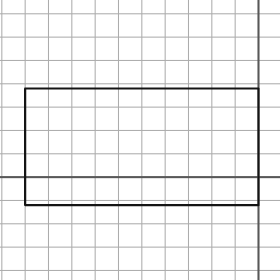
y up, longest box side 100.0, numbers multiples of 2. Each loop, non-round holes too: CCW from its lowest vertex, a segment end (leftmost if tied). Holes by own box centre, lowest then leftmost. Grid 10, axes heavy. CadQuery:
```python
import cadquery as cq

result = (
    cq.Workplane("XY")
    .moveTo(-100.0, -12.0)
    .lineTo(0.0, -12.0)
    .lineTo(0.0, 38.0)
    .lineTo(-100.0, 38.0)
    .close()
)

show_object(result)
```